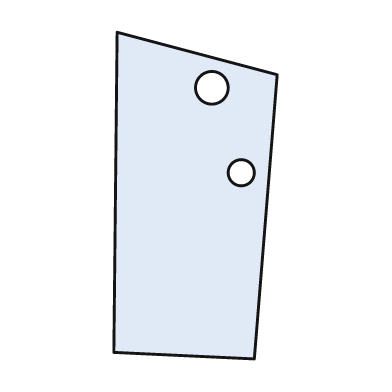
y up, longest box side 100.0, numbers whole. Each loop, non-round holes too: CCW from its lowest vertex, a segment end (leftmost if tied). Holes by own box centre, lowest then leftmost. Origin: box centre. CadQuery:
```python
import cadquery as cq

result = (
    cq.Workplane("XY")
    .moveTo(18.0, -50.0)
    .lineTo(25.0, 37.0)
    .lineTo(-24.0, 50.0)
    .lineTo(-25.0, -48.0)
    .close()
    .moveTo(14.0, 7.0)
    .circle(4.0)
    .moveTo(5.0, 33.0)
    .circle(5.0)
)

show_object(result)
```